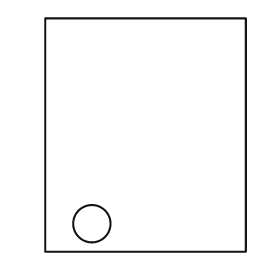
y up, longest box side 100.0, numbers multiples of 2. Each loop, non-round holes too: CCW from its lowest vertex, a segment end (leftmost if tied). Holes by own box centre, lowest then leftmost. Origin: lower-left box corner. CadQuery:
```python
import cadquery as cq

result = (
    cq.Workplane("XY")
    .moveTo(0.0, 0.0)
    .lineTo(86.0, 0.0)
    .lineTo(86.0, 100.0)
    .lineTo(0.0, 100.0)
    .close()
    .moveTo(20.0, 12.0)
    .circle(8.0)
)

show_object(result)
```